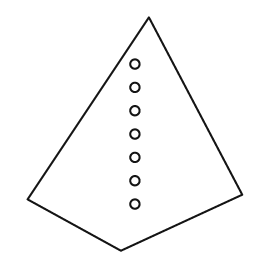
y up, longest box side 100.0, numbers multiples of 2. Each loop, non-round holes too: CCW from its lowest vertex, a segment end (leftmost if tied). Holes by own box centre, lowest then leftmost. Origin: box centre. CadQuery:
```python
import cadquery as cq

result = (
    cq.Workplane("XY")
    .moveTo(-6.0, -50.0)
    .lineTo(46.0, -26.0)
    .lineTo(6.0, 50.0)
    .lineTo(-46.0, -28.0)
    .close()
    .moveTo(0.0, -30.0)
    .circle(2.0)
    .moveTo(0.0, -20.0)
    .circle(2.0)
    .moveTo(0.0, -10.0)
    .circle(2.0)
    .moveTo(0.0, 0.0)
    .circle(2.0)
    .moveTo(0.0, 10.0)
    .circle(2.0)
    .moveTo(0.0, 20.0)
    .circle(2.0)
    .moveTo(0.0, 30.0)
    .circle(2.0)
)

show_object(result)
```